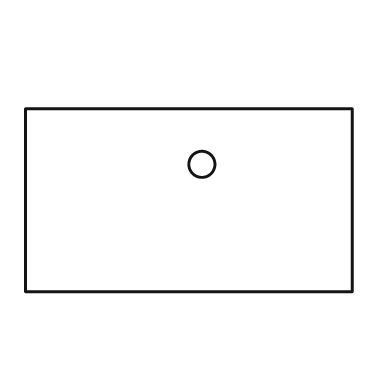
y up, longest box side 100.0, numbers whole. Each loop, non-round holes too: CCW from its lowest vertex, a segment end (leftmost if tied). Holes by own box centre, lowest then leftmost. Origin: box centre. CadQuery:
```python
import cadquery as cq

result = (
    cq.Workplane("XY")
    .moveTo(-50.0, -28.0)
    .lineTo(50.0, -28.0)
    .lineTo(50.0, 28.0)
    .lineTo(-50.0, 28.0)
    .close()
    .moveTo(4.0, 11.0)
    .circle(4.0)
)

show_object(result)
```